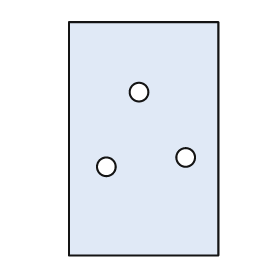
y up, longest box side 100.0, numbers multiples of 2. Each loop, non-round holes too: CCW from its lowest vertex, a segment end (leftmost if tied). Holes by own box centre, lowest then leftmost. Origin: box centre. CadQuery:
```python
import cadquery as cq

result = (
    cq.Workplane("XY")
    .moveTo(-32.0, -50.0)
    .lineTo(32.0, -50.0)
    .lineTo(32.0, 50.0)
    .lineTo(-32.0, 50.0)
    .close()
    .moveTo(-16.0, -12.0)
    .circle(4.0)
    .moveTo(18.0, -8.0)
    .circle(4.0)
    .moveTo(-2.0, 20.0)
    .circle(4.0)
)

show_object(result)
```